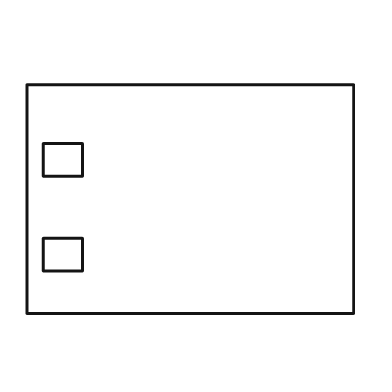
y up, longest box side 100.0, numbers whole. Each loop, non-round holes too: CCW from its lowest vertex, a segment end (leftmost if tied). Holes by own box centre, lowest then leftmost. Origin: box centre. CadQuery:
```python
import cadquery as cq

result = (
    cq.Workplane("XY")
    .moveTo(-50.0, -35.0)
    .lineTo(50.0, -35.0)
    .lineTo(50.0, 35.0)
    .lineTo(-50.0, 35.0)
    .close()
    .moveTo(-45.0, -22.0)
    .lineTo(-33.0, -22.0)
    .lineTo(-33.0, -12.0)
    .lineTo(-45.0, -12.0)
    .close()
    .moveTo(-45.0, 7.0)
    .lineTo(-33.0, 7.0)
    .lineTo(-33.0, 17.0)
    .lineTo(-45.0, 17.0)
    .close()
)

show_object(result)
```